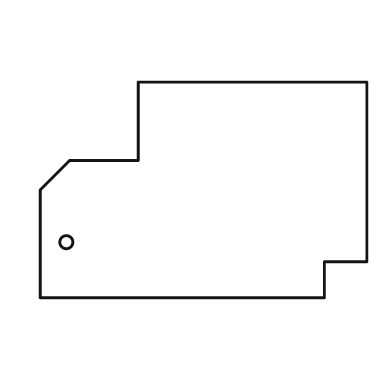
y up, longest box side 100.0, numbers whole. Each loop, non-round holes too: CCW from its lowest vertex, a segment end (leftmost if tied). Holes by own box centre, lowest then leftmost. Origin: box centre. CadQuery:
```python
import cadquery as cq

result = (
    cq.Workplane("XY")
    .moveTo(-50.0, -33.0)
    .lineTo(37.0, -33.0)
    .lineTo(37.0, -22.0)
    .lineTo(50.0, -22.0)
    .lineTo(50.0, 33.0)
    .lineTo(-20.0, 33.0)
    .lineTo(-20.0, 9.0)
    .lineTo(-41.0, 9.0)
    .lineTo(-50.0, 0.0)
    .close()
    .moveTo(-42.0, -16.0)
    .circle(2.0)
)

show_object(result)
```